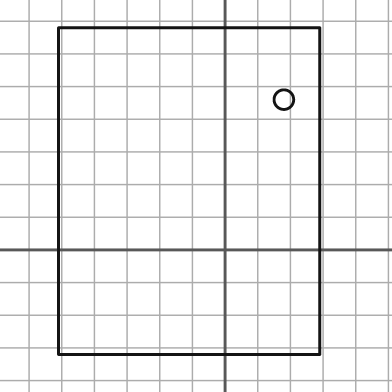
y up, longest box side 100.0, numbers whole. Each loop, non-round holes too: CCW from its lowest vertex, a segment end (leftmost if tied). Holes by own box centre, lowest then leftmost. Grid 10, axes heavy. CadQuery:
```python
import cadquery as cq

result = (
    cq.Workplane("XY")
    .moveTo(-51.0, -32.0)
    .lineTo(29.0, -32.0)
    .lineTo(29.0, 68.0)
    .lineTo(-51.0, 68.0)
    .close()
    .moveTo(18.0, 46.0)
    .circle(3.0)
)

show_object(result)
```